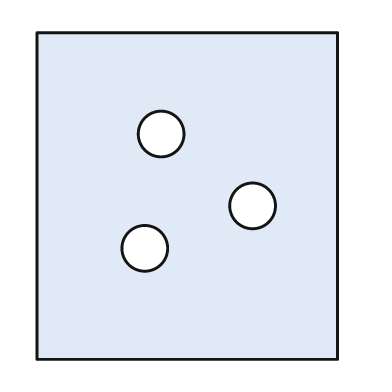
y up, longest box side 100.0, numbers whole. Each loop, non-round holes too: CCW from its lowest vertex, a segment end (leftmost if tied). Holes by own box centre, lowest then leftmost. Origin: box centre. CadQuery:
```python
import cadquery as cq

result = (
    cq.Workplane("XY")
    .moveTo(-46.0, -50.0)
    .lineTo(46.0, -50.0)
    .lineTo(46.0, 50.0)
    .lineTo(-46.0, 50.0)
    .close()
    .moveTo(-13.0, -16.0)
    .circle(7.0)
    .moveTo(20.0, -3.0)
    .circle(7.0)
    .moveTo(-8.0, 19.0)
    .circle(7.0)
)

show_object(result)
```